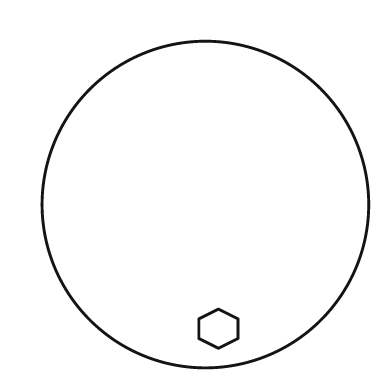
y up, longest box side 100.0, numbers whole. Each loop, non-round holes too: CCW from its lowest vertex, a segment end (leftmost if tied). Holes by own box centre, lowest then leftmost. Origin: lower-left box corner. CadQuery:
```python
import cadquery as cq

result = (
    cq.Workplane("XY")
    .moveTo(50.0, 50.0)
    .circle(50.0)
    .moveTo(54.0, 6.0)
    .lineTo(60.0, 9.0)
    .lineTo(60.0, 15.0)
    .lineTo(54.0, 18.0)
    .lineTo(48.0, 15.0)
    .lineTo(48.0, 9.0)
    .close()
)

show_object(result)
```